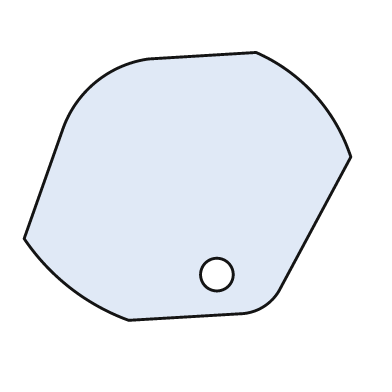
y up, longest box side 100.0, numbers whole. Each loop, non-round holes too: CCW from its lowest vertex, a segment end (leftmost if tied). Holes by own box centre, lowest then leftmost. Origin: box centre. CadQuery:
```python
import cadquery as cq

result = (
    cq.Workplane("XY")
    .moveTo(-18.0, -41.0)
    .lineTo(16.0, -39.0)
    .threePointArc((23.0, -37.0), (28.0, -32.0))
    .lineTo(50.0, 9.0)
    .threePointArc((39.0, 28.0), (21.0, 41.0))
    .lineTo(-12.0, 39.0)
    .threePointArc((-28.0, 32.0), (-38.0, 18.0))
    .lineTo(-50.0, -16.0)
    .threePointArc((-36.0, -31.0), (-18.0, -41.0))
    .close()
    .moveTo(9.0, -27.0)
    .circle(5.0)
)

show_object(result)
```